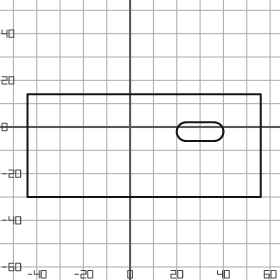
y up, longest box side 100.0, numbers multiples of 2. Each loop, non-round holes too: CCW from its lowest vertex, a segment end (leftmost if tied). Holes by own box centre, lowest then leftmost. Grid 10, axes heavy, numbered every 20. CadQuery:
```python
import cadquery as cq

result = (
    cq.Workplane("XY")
    .moveTo(-44.0, -30.0)
    .lineTo(56.0, -30.0)
    .lineTo(56.0, 14.0)
    .lineTo(-44.0, 14.0)
    .close()
    .moveTo(24.0, -6.0)
    .lineTo(36.0, -6.0)
    .threePointArc((40.0, -2.0), (36.0, 2.0))
    .lineTo(24.0, 2.0)
    .threePointArc((20.0, -2.0), (24.0, -6.0))
    .close()
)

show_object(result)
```